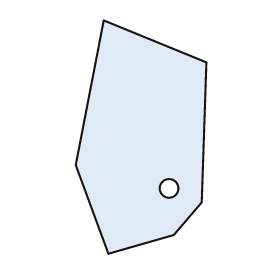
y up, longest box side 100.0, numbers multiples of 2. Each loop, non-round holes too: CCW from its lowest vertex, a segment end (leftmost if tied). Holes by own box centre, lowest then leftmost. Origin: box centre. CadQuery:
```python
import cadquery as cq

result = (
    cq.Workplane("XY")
    .moveTo(-14.0, -50.0)
    .lineTo(14.0, -42.0)
    .lineTo(26.0, -28.0)
    .lineTo(28.0, 32.0)
    .lineTo(-16.0, 50.0)
    .lineTo(-28.0, -12.0)
    .close()
    .moveTo(12.0, -22.0)
    .circle(4.0)
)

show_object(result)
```